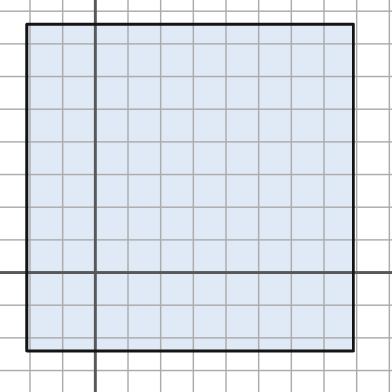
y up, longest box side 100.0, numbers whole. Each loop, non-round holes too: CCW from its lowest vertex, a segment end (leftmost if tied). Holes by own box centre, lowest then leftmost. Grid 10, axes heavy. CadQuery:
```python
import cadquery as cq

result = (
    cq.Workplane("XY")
    .moveTo(-21.0, -24.0)
    .lineTo(79.0, -24.0)
    .lineTo(79.0, 76.0)
    .lineTo(-21.0, 76.0)
    .close()
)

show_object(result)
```